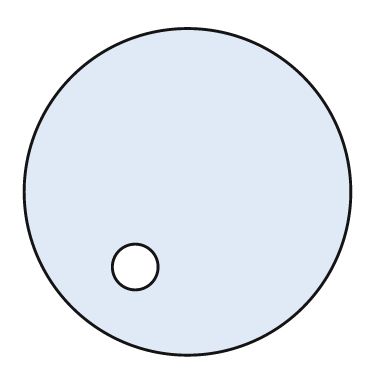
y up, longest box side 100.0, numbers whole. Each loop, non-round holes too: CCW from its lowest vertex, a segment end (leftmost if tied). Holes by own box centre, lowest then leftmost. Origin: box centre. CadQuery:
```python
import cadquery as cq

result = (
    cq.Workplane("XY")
    .moveTo(0.0, 0.0)
    .circle(50.0)
    .moveTo(-16.0, -23.0)
    .circle(7.0)
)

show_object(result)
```